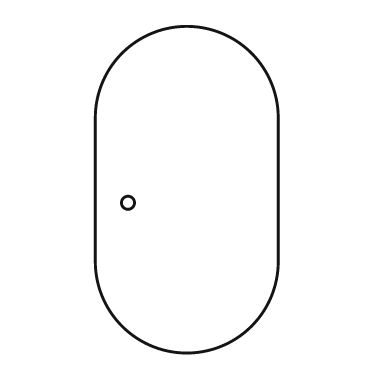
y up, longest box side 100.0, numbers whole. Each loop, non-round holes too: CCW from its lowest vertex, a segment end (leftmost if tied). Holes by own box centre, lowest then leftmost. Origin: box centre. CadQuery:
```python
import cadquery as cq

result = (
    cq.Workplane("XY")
    .moveTo(-28.0, -22.0)
    .threePointArc((0.0, -50.0), (28.0, -22.0))
    .lineTo(28.0, 22.0)
    .threePointArc((0.0, 50.0), (-28.0, 22.0))
    .close()
    .moveTo(-18.0, -4.0)
    .circle(2.0)
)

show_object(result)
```